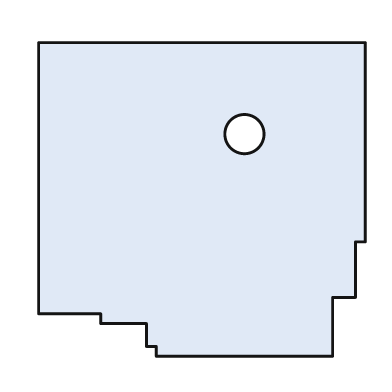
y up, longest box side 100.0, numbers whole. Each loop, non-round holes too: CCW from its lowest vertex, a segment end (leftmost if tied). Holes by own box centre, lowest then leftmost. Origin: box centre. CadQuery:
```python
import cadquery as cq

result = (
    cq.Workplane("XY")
    .moveTo(-14.0, -48.0)
    .lineTo(40.0, -48.0)
    .lineTo(40.0, -30.0)
    .lineTo(47.0, -30.0)
    .lineTo(47.0, -13.0)
    .lineTo(50.0, -13.0)
    .lineTo(50.0, 48.0)
    .lineTo(-50.0, 48.0)
    .lineTo(-50.0, -35.0)
    .lineTo(-31.0, -35.0)
    .lineTo(-31.0, -38.0)
    .lineTo(-17.0, -38.0)
    .lineTo(-17.0, -45.0)
    .lineTo(-14.0, -45.0)
    .close()
    .moveTo(13.0, 20.0)
    .circle(6.0)
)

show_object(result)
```